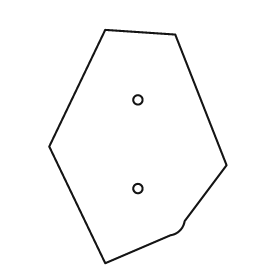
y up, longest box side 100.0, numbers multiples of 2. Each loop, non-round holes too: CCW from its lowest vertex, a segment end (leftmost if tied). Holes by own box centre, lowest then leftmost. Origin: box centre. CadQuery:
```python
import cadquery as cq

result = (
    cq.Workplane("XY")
    .moveTo(-14.0, -50.0)
    .lineTo(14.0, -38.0)
    .threePointArc((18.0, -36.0), (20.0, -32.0))
    .lineTo(38.0, -8.0)
    .lineTo(16.0, 48.0)
    .lineTo(-14.0, 50.0)
    .lineTo(-38.0, 0.0)
    .close()
    .moveTo(0.0, -18.0)
    .circle(2.0)
    .moveTo(0.0, 20.0)
    .circle(2.0)
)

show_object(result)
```